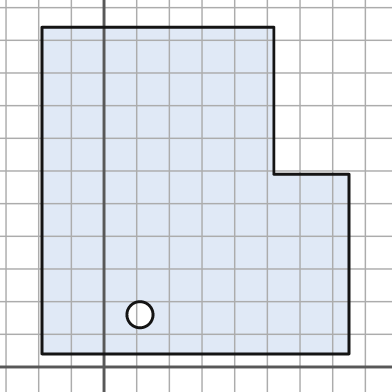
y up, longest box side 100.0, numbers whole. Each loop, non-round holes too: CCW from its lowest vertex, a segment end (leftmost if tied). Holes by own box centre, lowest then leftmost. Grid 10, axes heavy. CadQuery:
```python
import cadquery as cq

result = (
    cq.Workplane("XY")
    .moveTo(-19.0, 4.0)
    .lineTo(75.0, 4.0)
    .lineTo(75.0, 59.0)
    .lineTo(52.0, 59.0)
    .lineTo(52.0, 104.0)
    .lineTo(-19.0, 104.0)
    .close()
    .moveTo(11.0, 16.0)
    .circle(4.0)
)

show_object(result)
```